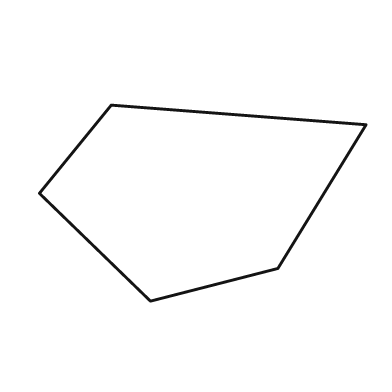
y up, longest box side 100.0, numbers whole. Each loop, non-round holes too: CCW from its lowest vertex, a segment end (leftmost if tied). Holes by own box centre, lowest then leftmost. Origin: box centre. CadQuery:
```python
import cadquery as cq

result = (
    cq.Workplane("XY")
    .moveTo(-16.0, -30.0)
    .lineTo(23.0, -20.0)
    .lineTo(50.0, 24.0)
    .lineTo(-28.0, 30.0)
    .lineTo(-50.0, 3.0)
    .close()
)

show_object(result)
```